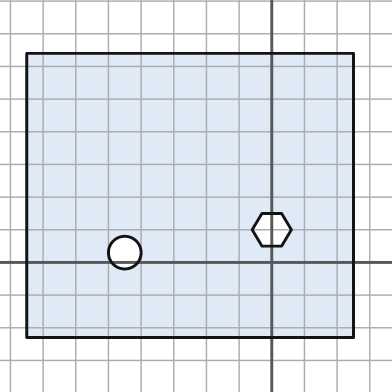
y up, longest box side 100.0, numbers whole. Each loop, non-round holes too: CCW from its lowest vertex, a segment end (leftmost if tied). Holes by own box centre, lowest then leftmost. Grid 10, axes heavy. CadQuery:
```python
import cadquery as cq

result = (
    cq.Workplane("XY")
    .moveTo(-75.0, -23.0)
    .lineTo(25.0, -23.0)
    .lineTo(25.0, 64.0)
    .lineTo(-75.0, 64.0)
    .close()
    .moveTo(-45.0, 3.0)
    .circle(5.0)
    .moveTo(-3.0, 5.0)
    .lineTo(3.0, 5.0)
    .lineTo(6.0, 10.0)
    .lineTo(3.0, 15.0)
    .lineTo(-3.0, 15.0)
    .lineTo(-6.0, 10.0)
    .close()
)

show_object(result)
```